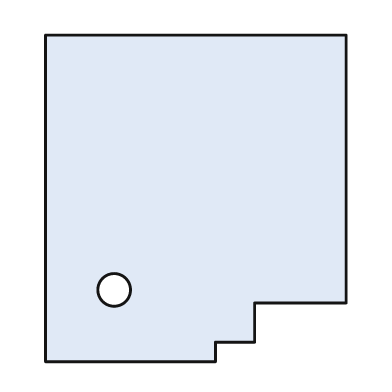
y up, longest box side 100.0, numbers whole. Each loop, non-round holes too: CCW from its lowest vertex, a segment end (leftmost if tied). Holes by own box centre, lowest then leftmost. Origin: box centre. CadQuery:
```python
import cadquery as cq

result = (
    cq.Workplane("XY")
    .moveTo(-46.0, -50.0)
    .lineTo(6.0, -50.0)
    .lineTo(6.0, -44.0)
    .lineTo(18.0, -44.0)
    .lineTo(18.0, -32.0)
    .lineTo(46.0, -32.0)
    .lineTo(46.0, 50.0)
    .lineTo(-46.0, 50.0)
    .close()
    .moveTo(-25.0, -28.0)
    .circle(5.0)
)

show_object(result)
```